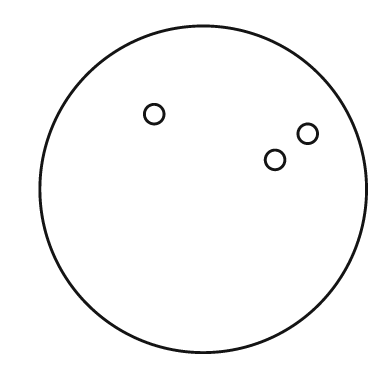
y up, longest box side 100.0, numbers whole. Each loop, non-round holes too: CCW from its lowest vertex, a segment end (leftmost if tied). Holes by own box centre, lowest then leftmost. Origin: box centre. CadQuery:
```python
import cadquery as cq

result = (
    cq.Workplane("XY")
    .moveTo(0.0, 0.0)
    .circle(50.0)
    .moveTo(22.0, 9.0)
    .circle(3.0)
    .moveTo(32.0, 17.0)
    .circle(3.0)
    .moveTo(-15.0, 23.0)
    .circle(3.0)
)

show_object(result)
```